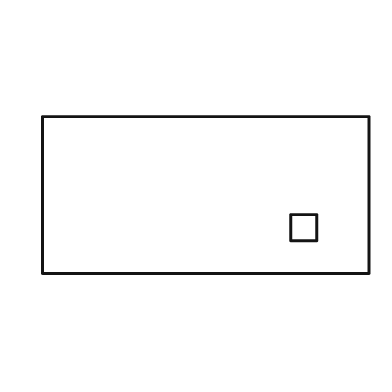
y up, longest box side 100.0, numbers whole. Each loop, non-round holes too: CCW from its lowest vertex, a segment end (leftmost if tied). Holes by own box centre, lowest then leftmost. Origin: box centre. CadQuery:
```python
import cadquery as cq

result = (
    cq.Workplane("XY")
    .moveTo(-50.0, -24.0)
    .lineTo(50.0, -24.0)
    .lineTo(50.0, 24.0)
    .lineTo(-50.0, 24.0)
    .close()
    .moveTo(26.0, -14.0)
    .lineTo(34.0, -14.0)
    .lineTo(34.0, -6.0)
    .lineTo(26.0, -6.0)
    .close()
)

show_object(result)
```